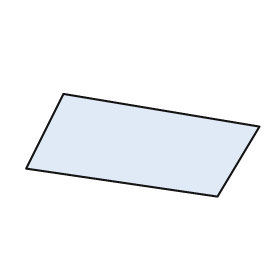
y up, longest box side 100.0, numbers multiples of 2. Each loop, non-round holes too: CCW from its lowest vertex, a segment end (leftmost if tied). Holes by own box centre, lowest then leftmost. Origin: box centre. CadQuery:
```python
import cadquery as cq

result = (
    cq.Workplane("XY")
    .moveTo(32.0, -22.0)
    .lineTo(50.0, 8.0)
    .lineTo(-34.0, 22.0)
    .lineTo(-50.0, -10.0)
    .close()
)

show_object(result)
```